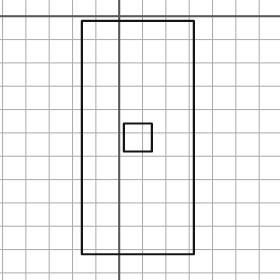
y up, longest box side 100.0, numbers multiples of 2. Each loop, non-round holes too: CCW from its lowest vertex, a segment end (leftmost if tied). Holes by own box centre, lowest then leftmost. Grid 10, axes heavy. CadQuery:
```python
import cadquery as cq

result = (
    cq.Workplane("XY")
    .moveTo(-16.0, -102.0)
    .lineTo(32.0, -102.0)
    .lineTo(32.0, -2.0)
    .lineTo(-16.0, -2.0)
    .close()
    .moveTo(2.0, -58.0)
    .lineTo(14.0, -58.0)
    .lineTo(14.0, -46.0)
    .lineTo(2.0, -46.0)
    .close()
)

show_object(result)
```